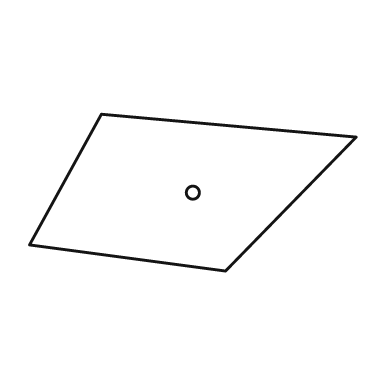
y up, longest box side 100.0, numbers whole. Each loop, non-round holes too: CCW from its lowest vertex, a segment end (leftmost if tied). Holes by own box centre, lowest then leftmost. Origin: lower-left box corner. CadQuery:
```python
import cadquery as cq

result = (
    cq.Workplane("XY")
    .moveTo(60.0, 0.0)
    .lineTo(100.0, 41.0)
    .lineTo(22.0, 48.0)
    .lineTo(0.0, 8.0)
    .close()
    .moveTo(50.0, 24.0)
    .circle(2.0)
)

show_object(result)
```